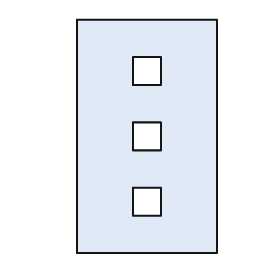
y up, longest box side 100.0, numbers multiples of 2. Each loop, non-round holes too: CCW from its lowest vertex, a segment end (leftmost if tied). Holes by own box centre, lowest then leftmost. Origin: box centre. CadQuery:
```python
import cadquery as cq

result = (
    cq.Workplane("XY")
    .moveTo(-30.0, -50.0)
    .lineTo(30.0, -50.0)
    .lineTo(30.0, 50.0)
    .lineTo(-30.0, 50.0)
    .close()
    .moveTo(-6.0, -34.0)
    .lineTo(6.0, -34.0)
    .lineTo(6.0, -22.0)
    .lineTo(-6.0, -22.0)
    .close()
    .moveTo(-6.0, -6.0)
    .lineTo(6.0, -6.0)
    .lineTo(6.0, 6.0)
    .lineTo(-6.0, 6.0)
    .close()
    .moveTo(-6.0, 22.0)
    .lineTo(6.0, 22.0)
    .lineTo(6.0, 34.0)
    .lineTo(-6.0, 34.0)
    .close()
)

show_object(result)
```